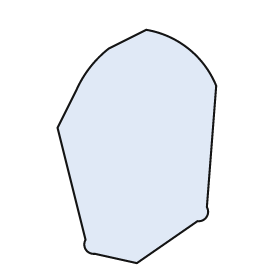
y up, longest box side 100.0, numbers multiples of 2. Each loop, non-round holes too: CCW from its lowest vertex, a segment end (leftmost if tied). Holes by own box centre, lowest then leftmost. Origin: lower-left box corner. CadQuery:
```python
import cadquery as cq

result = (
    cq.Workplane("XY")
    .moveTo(34.0, 0.0)
    .lineTo(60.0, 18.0)
    .threePointArc((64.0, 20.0), (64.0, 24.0))
    .lineTo(68.0, 76.0)
    .threePointArc((56.0, 92.0), (38.0, 100.0))
    .lineTo(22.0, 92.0)
    .threePointArc((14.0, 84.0), (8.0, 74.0))
    .lineTo(0.0, 58.0)
    .lineTo(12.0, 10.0)
    .threePointArc((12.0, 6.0), (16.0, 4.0))
    .close()
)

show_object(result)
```